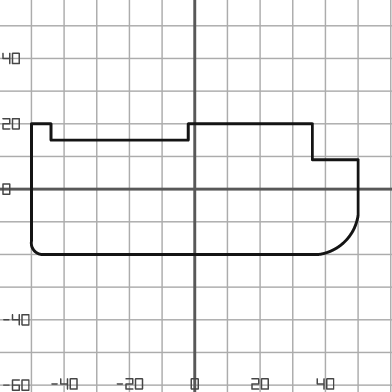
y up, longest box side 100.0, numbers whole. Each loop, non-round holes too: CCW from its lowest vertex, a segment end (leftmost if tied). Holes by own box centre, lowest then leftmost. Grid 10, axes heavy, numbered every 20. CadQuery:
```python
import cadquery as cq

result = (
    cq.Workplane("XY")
    .moveTo(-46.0, -20.0)
    .lineTo(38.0, -20.0)
    .threePointArc((46.0, -16.0), (50.0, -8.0))
    .lineTo(50.0, 9.0)
    .lineTo(36.0, 9.0)
    .lineTo(36.0, 20.0)
    .lineTo(-2.0, 20.0)
    .lineTo(-2.0, 15.0)
    .lineTo(-44.0, 15.0)
    .lineTo(-44.0, 20.0)
    .lineTo(-50.0, 20.0)
    .lineTo(-50.0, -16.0)
    .threePointArc((-49.0, -19.0), (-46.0, -20.0))
    .close()
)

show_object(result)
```